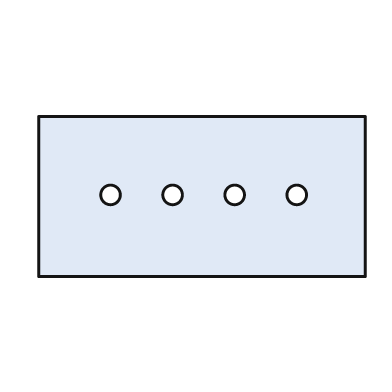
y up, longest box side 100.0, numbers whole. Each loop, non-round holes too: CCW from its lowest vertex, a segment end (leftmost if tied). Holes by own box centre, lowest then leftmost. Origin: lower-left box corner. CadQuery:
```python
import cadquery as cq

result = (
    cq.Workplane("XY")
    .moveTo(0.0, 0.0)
    .lineTo(100.0, 0.0)
    .lineTo(100.0, 49.0)
    .lineTo(0.0, 49.0)
    .close()
    .moveTo(22.0, 25.0)
    .circle(3.0)
    .moveTo(41.0, 25.0)
    .circle(3.0)
    .moveTo(60.0, 25.0)
    .circle(3.0)
    .moveTo(79.0, 25.0)
    .circle(3.0)
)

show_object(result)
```